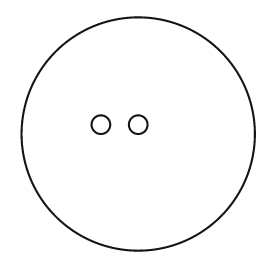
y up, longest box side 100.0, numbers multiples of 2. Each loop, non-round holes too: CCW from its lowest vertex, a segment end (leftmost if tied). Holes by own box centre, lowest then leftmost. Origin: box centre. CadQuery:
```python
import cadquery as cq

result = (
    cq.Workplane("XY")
    .moveTo(0.0, 0.0)
    .circle(50.0)
    .moveTo(-16.0, 4.0)
    .circle(4.0)
    .moveTo(0.0, 4.0)
    .circle(4.0)
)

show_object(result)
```